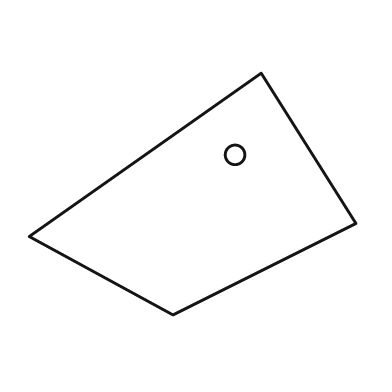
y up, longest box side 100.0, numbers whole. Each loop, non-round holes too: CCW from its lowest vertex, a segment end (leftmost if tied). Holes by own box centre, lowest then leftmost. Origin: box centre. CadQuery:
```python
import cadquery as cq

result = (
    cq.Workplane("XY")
    .moveTo(-6.0, -37.0)
    .lineTo(50.0, -9.0)
    .lineTo(21.0, 37.0)
    .lineTo(-50.0, -13.0)
    .close()
    .moveTo(13.0, 12.0)
    .circle(3.0)
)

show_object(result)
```